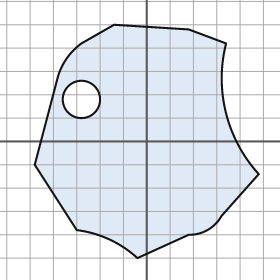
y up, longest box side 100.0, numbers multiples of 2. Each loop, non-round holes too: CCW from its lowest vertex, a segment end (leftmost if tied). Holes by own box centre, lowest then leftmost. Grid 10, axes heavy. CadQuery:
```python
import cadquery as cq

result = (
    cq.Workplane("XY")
    .moveTo(-4.0, -50.0)
    .lineTo(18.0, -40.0)
    .threePointArc((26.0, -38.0), (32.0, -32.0))
    .lineTo(48.0, -14.0)
    .threePointArc((34.0, 12.0), (34.0, 42.0))
    .lineTo(18.0, 48.0)
    .lineTo(-14.0, 50.0)
    .lineTo(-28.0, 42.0)
    .threePointArc((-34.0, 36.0), (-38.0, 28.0))
    .lineTo(-48.0, -10.0)
    .lineTo(-30.0, -38.0)
    .threePointArc((-16.0, -42.0), (-4.0, -50.0))
    .close()
    .moveTo(-28.0, 18.0)
    .circle(8.0)
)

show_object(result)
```